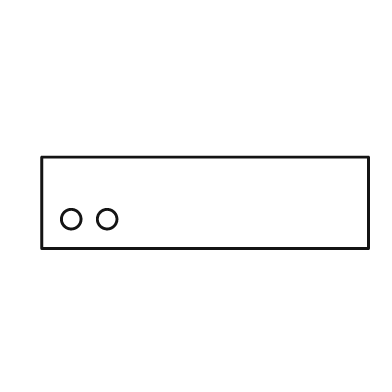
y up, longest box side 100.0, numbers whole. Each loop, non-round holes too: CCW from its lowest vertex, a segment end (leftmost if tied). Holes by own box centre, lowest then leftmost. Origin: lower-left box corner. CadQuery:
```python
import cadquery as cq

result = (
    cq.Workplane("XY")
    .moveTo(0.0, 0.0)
    .lineTo(100.0, 0.0)
    .lineTo(100.0, 28.0)
    .lineTo(0.0, 28.0)
    .close()
    .moveTo(9.0, 9.0)
    .circle(3.0)
    .moveTo(20.0, 9.0)
    .circle(3.0)
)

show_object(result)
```